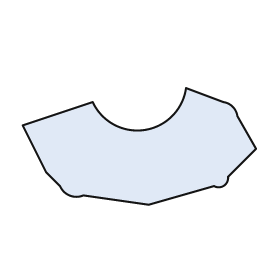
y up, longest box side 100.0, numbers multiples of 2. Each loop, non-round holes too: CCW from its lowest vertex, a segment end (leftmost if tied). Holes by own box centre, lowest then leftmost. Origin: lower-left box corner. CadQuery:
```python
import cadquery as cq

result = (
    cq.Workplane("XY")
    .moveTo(54.0, 0.0)
    .lineTo(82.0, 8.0)
    .threePointArc((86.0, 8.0), (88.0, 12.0))
    .lineTo(100.0, 24.0)
    .lineTo(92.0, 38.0)
    .threePointArc((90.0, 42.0), (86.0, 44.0))
    .lineTo(70.0, 50.0)
    .threePointArc((52.0, 32.0), (30.0, 44.0))
    .lineTo(0.0, 34.0)
    .lineTo(10.0, 14.0)
    .lineTo(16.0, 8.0)
    .threePointArc((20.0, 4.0), (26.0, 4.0))
    .close()
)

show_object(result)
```